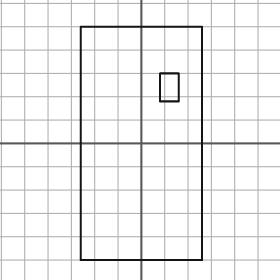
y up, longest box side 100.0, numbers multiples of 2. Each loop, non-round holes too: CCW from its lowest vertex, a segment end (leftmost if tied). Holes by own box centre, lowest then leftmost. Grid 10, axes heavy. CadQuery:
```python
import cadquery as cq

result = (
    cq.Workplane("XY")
    .moveTo(-26.0, -50.0)
    .lineTo(26.0, -50.0)
    .lineTo(26.0, 50.0)
    .lineTo(-26.0, 50.0)
    .close()
    .moveTo(8.0, 18.0)
    .lineTo(16.0, 18.0)
    .lineTo(16.0, 30.0)
    .lineTo(8.0, 30.0)
    .close()
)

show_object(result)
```